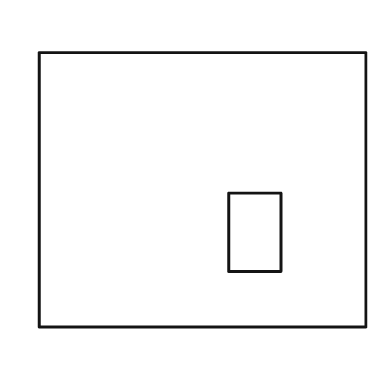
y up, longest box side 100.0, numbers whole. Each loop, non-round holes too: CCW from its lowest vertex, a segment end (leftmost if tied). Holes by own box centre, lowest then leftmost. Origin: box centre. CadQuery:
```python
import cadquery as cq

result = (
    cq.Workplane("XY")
    .moveTo(-50.0, -42.0)
    .lineTo(50.0, -42.0)
    .lineTo(50.0, 42.0)
    .lineTo(-50.0, 42.0)
    .close()
    .moveTo(8.0, -25.0)
    .lineTo(24.0, -25.0)
    .lineTo(24.0, -1.0)
    .lineTo(8.0, -1.0)
    .close()
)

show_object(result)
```